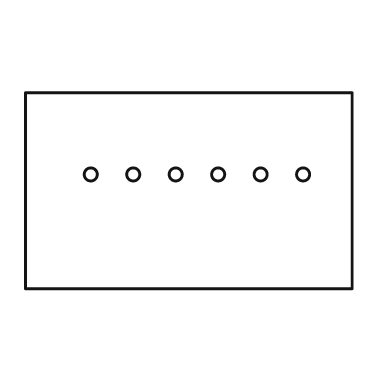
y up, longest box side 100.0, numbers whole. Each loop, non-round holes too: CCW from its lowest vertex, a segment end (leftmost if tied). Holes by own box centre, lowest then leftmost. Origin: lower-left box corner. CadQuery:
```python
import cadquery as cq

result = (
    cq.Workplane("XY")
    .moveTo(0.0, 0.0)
    .lineTo(100.0, 0.0)
    .lineTo(100.0, 60.0)
    .lineTo(0.0, 60.0)
    .close()
    .moveTo(20.0, 35.0)
    .circle(2.0)
    .moveTo(33.0, 35.0)
    .circle(2.0)
    .moveTo(46.0, 35.0)
    .circle(2.0)
    .moveTo(59.0, 35.0)
    .circle(2.0)
    .moveTo(72.0, 35.0)
    .circle(2.0)
    .moveTo(85.0, 35.0)
    .circle(2.0)
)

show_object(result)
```